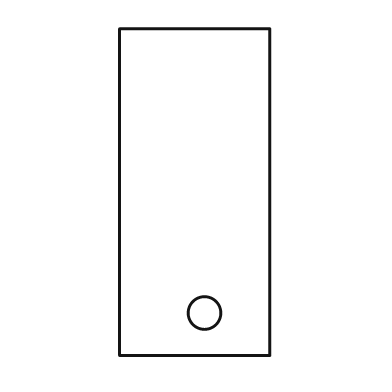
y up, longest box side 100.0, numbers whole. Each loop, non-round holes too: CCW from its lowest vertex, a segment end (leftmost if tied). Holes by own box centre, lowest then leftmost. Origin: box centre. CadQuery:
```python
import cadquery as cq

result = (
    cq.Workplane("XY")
    .moveTo(-23.0, -50.0)
    .lineTo(23.0, -50.0)
    .lineTo(23.0, 50.0)
    .lineTo(-23.0, 50.0)
    .close()
    .moveTo(3.0, -37.0)
    .circle(5.0)
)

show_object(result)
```